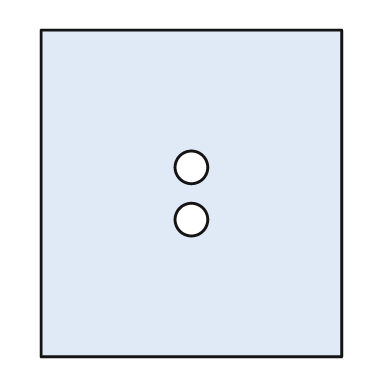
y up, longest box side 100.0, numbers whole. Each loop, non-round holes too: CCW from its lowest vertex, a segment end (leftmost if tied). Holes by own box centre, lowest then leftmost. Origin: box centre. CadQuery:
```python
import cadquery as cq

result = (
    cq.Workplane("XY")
    .moveTo(-46.0, -50.0)
    .lineTo(46.0, -50.0)
    .lineTo(46.0, 50.0)
    .lineTo(-46.0, 50.0)
    .close()
    .moveTo(0.0, -8.0)
    .circle(5.0)
    .moveTo(0.0, 8.0)
    .circle(5.0)
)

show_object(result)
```